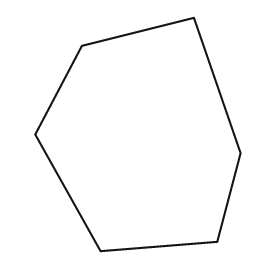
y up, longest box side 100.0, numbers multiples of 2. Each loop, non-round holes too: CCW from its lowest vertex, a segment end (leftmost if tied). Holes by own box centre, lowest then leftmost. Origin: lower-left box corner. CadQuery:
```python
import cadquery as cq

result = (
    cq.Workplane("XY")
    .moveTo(28.0, 0.0)
    .lineTo(78.0, 4.0)
    .lineTo(88.0, 42.0)
    .lineTo(68.0, 100.0)
    .lineTo(20.0, 88.0)
    .lineTo(0.0, 50.0)
    .close()
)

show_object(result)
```